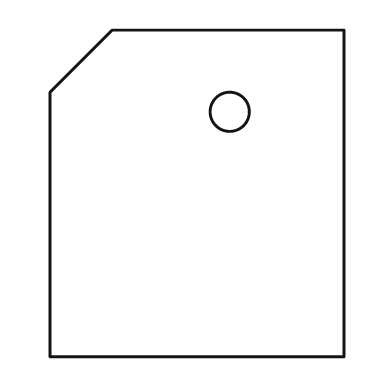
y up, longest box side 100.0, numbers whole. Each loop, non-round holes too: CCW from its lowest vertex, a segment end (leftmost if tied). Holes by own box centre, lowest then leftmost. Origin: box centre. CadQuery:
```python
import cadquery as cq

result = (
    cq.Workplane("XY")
    .moveTo(-45.0, -50.0)
    .lineTo(45.0, -50.0)
    .lineTo(45.0, 50.0)
    .lineTo(-26.0, 50.0)
    .lineTo(-45.0, 31.0)
    .close()
    .moveTo(10.0, 25.0)
    .circle(6.0)
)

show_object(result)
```